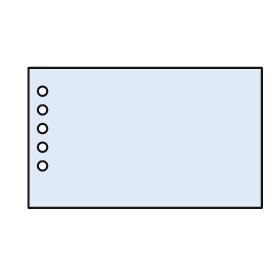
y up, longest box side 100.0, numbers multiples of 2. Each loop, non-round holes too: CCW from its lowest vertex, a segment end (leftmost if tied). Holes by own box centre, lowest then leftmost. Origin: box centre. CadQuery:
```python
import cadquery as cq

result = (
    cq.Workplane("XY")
    .moveTo(-50.0, -30.0)
    .lineTo(50.0, -30.0)
    .lineTo(50.0, 30.0)
    .lineTo(-50.0, 30.0)
    .close()
    .moveTo(-44.0, -12.0)
    .circle(2.0)
    .moveTo(-44.0, -4.0)
    .circle(2.0)
    .moveTo(-44.0, 4.0)
    .circle(2.0)
    .moveTo(-44.0, 12.0)
    .circle(2.0)
    .moveTo(-44.0, 20.0)
    .circle(2.0)
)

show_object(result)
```